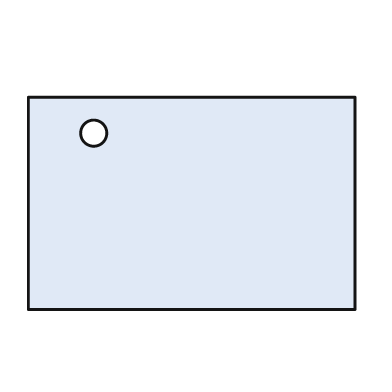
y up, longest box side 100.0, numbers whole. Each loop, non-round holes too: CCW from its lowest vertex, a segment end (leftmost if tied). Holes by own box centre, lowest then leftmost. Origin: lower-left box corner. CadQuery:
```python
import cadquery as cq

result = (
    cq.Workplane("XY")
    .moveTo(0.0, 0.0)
    .lineTo(100.0, 0.0)
    .lineTo(100.0, 65.0)
    .lineTo(0.0, 65.0)
    .close()
    .moveTo(20.0, 54.0)
    .circle(4.0)
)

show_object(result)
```